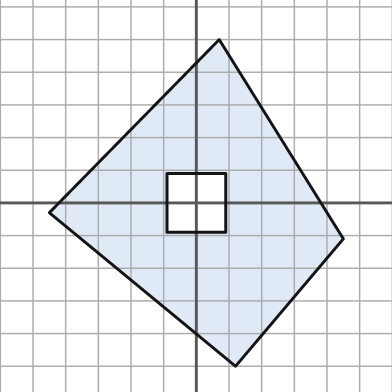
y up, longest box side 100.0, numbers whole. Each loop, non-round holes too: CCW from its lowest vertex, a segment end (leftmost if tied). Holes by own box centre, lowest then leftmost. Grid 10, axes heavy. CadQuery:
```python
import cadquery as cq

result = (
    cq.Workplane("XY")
    .moveTo(12.0, -50.0)
    .lineTo(45.0, -11.0)
    .lineTo(7.0, 50.0)
    .lineTo(-45.0, -3.0)
    .close()
    .moveTo(-9.0, -9.0)
    .lineTo(9.0, -9.0)
    .lineTo(9.0, 9.0)
    .lineTo(-9.0, 9.0)
    .close()
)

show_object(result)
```